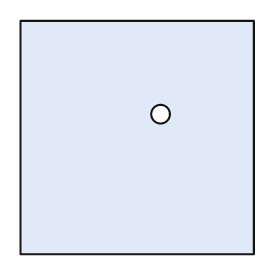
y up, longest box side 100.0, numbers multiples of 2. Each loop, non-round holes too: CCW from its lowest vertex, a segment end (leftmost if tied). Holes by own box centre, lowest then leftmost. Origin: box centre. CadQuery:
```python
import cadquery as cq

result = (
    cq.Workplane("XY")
    .moveTo(-50.0, -50.0)
    .lineTo(50.0, -50.0)
    .lineTo(50.0, 50.0)
    .lineTo(-50.0, 50.0)
    .close()
    .moveTo(10.0, 10.0)
    .circle(4.0)
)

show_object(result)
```